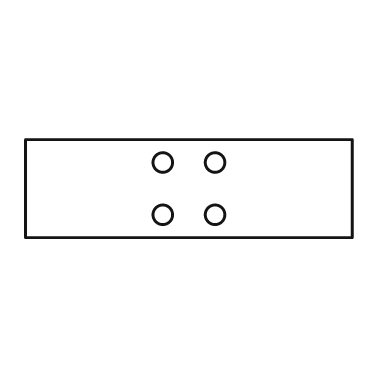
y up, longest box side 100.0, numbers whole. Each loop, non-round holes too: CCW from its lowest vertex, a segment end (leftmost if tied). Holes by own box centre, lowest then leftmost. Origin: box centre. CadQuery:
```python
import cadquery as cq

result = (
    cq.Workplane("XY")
    .moveTo(-50.0, -15.0)
    .lineTo(50.0, -15.0)
    .lineTo(50.0, 15.0)
    .lineTo(-50.0, 15.0)
    .close()
    .moveTo(-8.0, -8.0)
    .circle(3.0)
    .moveTo(8.0, -8.0)
    .circle(3.0)
    .moveTo(-8.0, 8.0)
    .circle(3.0)
    .moveTo(8.0, 8.0)
    .circle(3.0)
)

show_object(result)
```